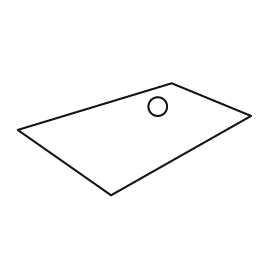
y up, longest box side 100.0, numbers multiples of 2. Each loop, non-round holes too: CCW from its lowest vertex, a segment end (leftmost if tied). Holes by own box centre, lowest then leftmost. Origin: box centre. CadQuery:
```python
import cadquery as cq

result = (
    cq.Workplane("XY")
    .moveTo(-10.0, -24.0)
    .lineTo(50.0, 10.0)
    .lineTo(16.0, 24.0)
    .lineTo(-50.0, 4.0)
    .close()
    .moveTo(10.0, 14.0)
    .circle(4.0)
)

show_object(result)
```